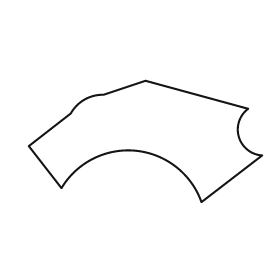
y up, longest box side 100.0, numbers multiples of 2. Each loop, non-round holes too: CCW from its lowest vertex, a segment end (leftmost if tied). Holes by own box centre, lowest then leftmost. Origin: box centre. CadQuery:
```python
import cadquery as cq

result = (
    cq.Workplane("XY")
    .moveTo(24.0, -26.0)
    .lineTo(50.0, -6.0)
    .threePointArc((40.0, 2.0), (44.0, 14.0))
    .lineTo(0.0, 26.0)
    .lineTo(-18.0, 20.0)
    .threePointArc((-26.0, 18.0), (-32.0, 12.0))
    .lineTo(-50.0, -2.0)
    .lineTo(-36.0, -20.0)
    .threePointArc((-4.0, -4.0), (24.0, -26.0))
    .close()
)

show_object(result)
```